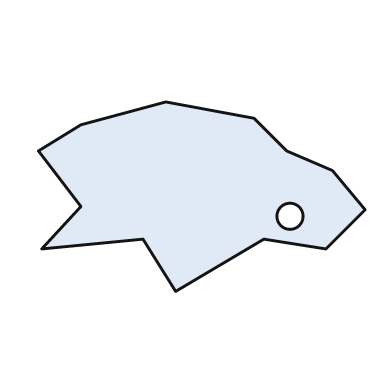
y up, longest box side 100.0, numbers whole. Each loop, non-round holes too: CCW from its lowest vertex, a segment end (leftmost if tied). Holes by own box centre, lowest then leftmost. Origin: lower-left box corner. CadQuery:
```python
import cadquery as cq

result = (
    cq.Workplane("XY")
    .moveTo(42.0, 0.0)
    .lineTo(69.0, 16.0)
    .lineTo(88.0, 13.0)
    .lineTo(100.0, 25.0)
    .lineTo(90.0, 37.0)
    .lineTo(76.0, 43.0)
    .lineTo(66.0, 53.0)
    .lineTo(39.0, 58.0)
    .lineTo(13.0, 51.0)
    .lineTo(0.0, 43.0)
    .lineTo(13.0, 26.0)
    .lineTo(1.0, 13.0)
    .lineTo(32.0, 16.0)
    .close()
    .moveTo(77.0, 23.0)
    .circle(4.0)
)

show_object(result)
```